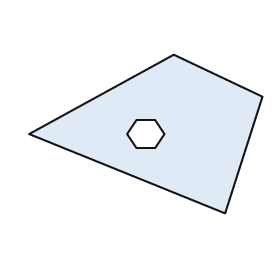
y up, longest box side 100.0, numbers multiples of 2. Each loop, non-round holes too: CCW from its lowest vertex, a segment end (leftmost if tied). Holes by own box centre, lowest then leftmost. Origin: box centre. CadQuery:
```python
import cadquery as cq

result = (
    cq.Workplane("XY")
    .moveTo(34.0, -34.0)
    .lineTo(50.0, 16.0)
    .lineTo(12.0, 34.0)
    .lineTo(-50.0, 0.0)
    .close()
    .moveTo(-4.0, -6.0)
    .lineTo(4.0, -6.0)
    .lineTo(8.0, 0.0)
    .lineTo(4.0, 6.0)
    .lineTo(-4.0, 6.0)
    .lineTo(-8.0, 0.0)
    .close()
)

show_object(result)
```